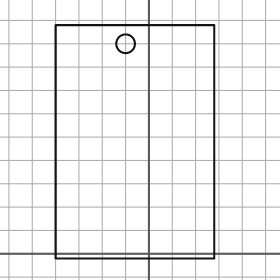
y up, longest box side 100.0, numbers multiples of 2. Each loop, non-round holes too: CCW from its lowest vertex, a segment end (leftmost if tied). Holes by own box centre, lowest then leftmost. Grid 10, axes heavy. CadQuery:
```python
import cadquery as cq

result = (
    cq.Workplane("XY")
    .moveTo(-40.0, -2.0)
    .lineTo(28.0, -2.0)
    .lineTo(28.0, 98.0)
    .lineTo(-40.0, 98.0)
    .close()
    .moveTo(-10.0, 90.0)
    .circle(4.0)
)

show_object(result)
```